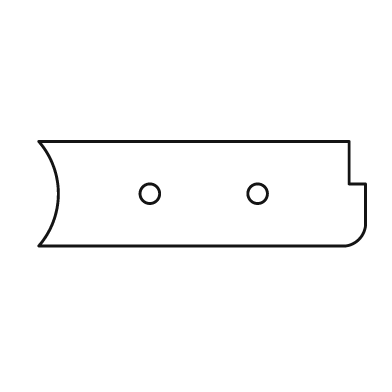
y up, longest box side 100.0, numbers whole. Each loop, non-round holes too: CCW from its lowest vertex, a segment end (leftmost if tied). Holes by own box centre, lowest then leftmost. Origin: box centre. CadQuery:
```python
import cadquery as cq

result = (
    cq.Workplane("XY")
    .moveTo(-50.0, -16.0)
    .lineTo(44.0, -16.0)
    .threePointArc((48.0, -14.0), (50.0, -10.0))
    .lineTo(50.0, 3.0)
    .lineTo(45.0, 3.0)
    .lineTo(45.0, 16.0)
    .lineTo(-50.0, 16.0)
    .threePointArc((-44.0, 0.0), (-50.0, -16.0))
    .close()
    .moveTo(-16.0, 0.0)
    .circle(3.0)
    .moveTo(17.0, 0.0)
    .circle(3.0)
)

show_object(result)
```